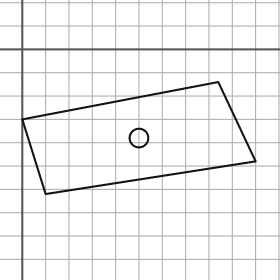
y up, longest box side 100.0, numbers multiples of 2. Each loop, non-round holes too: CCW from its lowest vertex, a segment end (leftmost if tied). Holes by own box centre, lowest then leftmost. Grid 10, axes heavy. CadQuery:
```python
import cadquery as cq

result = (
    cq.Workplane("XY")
    .moveTo(10.0, -62.0)
    .lineTo(100.0, -48.0)
    .lineTo(84.0, -14.0)
    .lineTo(0.0, -30.0)
    .close()
    .moveTo(50.0, -38.0)
    .circle(4.0)
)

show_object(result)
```